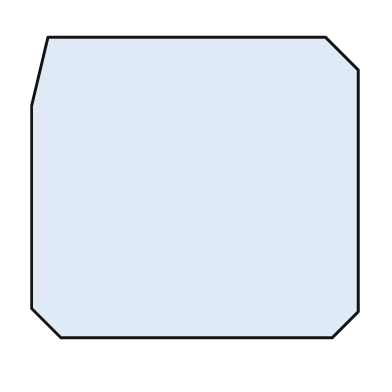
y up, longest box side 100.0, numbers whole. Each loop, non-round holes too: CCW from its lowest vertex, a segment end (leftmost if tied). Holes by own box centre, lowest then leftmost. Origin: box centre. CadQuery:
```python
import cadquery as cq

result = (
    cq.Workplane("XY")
    .moveTo(-41.0, -46.0)
    .lineTo(42.0, -46.0)
    .lineTo(50.0, -38.0)
    .lineTo(50.0, 36.0)
    .lineTo(40.0, 46.0)
    .lineTo(-45.0, 46.0)
    .lineTo(-50.0, 25.0)
    .lineTo(-50.0, -37.0)
    .close()
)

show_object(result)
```